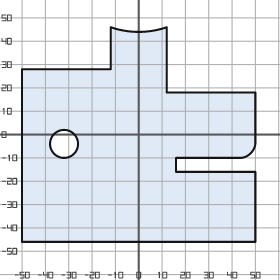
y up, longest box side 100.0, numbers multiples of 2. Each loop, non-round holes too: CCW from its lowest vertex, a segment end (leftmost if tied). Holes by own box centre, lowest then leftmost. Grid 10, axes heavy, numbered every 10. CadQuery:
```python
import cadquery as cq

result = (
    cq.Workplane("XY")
    .moveTo(-50.0, -46.0)
    .lineTo(50.0, -46.0)
    .lineTo(50.0, -16.0)
    .lineTo(16.0, -16.0)
    .lineTo(16.0, -10.0)
    .lineTo(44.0, -10.0)
    .threePointArc((48.0, -8.0), (50.0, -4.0))
    .lineTo(50.0, 18.0)
    .lineTo(12.0, 18.0)
    .lineTo(12.0, 46.0)
    .threePointArc((0.0, 44.0), (-12.0, 46.0))
    .lineTo(-12.0, 28.0)
    .lineTo(-50.0, 28.0)
    .close()
    .moveTo(-32.0, -4.0)
    .circle(6.0)
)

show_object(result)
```